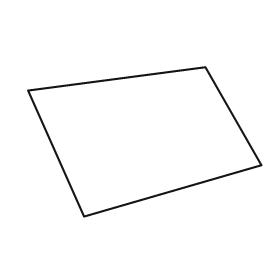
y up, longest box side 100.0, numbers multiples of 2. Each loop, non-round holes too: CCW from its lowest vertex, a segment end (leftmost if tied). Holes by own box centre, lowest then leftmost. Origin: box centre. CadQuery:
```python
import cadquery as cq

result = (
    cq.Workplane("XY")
    .moveTo(-26.0, -32.0)
    .lineTo(50.0, -10.0)
    .lineTo(26.0, 32.0)
    .lineTo(-50.0, 22.0)
    .close()
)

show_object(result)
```